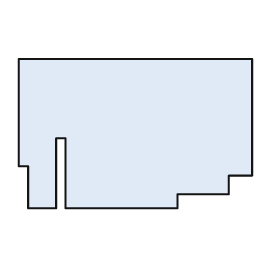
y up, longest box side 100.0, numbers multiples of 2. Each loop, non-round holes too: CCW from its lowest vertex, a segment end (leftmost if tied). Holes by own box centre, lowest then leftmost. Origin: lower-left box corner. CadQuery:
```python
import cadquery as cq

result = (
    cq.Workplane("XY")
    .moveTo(4.0, 0.0)
    .lineTo(16.0, 0.0)
    .lineTo(16.0, 30.0)
    .lineTo(20.0, 30.0)
    .lineTo(20.0, 0.0)
    .lineTo(68.0, 0.0)
    .lineTo(68.0, 6.0)
    .lineTo(90.0, 6.0)
    .lineTo(90.0, 14.0)
    .lineTo(100.0, 14.0)
    .lineTo(100.0, 64.0)
    .lineTo(0.0, 64.0)
    .lineTo(0.0, 18.0)
    .lineTo(4.0, 18.0)
    .close()
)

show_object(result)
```